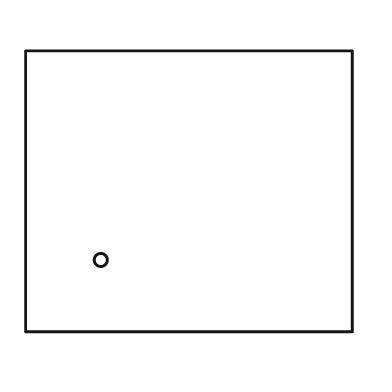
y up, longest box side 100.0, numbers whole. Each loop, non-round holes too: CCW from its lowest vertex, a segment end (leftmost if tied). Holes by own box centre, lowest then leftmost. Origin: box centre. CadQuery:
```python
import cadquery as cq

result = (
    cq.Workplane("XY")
    .moveTo(-50.0, -43.0)
    .lineTo(50.0, -43.0)
    .lineTo(50.0, 43.0)
    .lineTo(-50.0, 43.0)
    .close()
    .moveTo(-27.0, -21.0)
    .circle(2.0)
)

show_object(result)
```